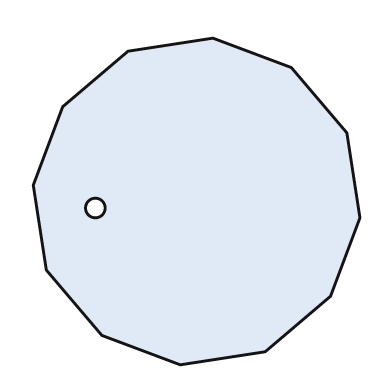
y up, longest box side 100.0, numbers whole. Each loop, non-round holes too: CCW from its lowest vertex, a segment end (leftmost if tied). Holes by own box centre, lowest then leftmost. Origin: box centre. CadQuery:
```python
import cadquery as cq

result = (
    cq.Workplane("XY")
    .moveTo(-5.0, -50.0)
    .lineTo(21.0, -46.0)
    .lineTo(41.0, -29.0)
    .lineTo(50.0, -5.0)
    .lineTo(46.0, 21.0)
    .lineTo(29.0, 41.0)
    .lineTo(5.0, 50.0)
    .lineTo(-21.0, 46.0)
    .lineTo(-41.0, 29.0)
    .lineTo(-50.0, 5.0)
    .lineTo(-46.0, -21.0)
    .lineTo(-29.0, -41.0)
    .close()
    .moveTo(-31.0, -2.0)
    .circle(3.0)
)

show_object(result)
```